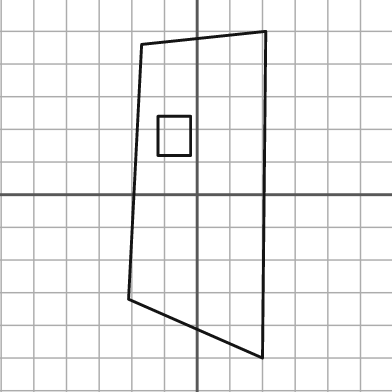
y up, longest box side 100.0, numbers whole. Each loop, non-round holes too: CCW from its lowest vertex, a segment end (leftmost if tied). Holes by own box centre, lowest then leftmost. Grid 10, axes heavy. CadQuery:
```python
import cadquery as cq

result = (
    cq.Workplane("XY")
    .moveTo(20.0, -50.0)
    .lineTo(21.0, 50.0)
    .lineTo(-17.0, 46.0)
    .lineTo(-21.0, -32.0)
    .close()
    .moveTo(-12.0, 12.0)
    .lineTo(-2.0, 12.0)
    .lineTo(-2.0, 24.0)
    .lineTo(-12.0, 24.0)
    .close()
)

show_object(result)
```